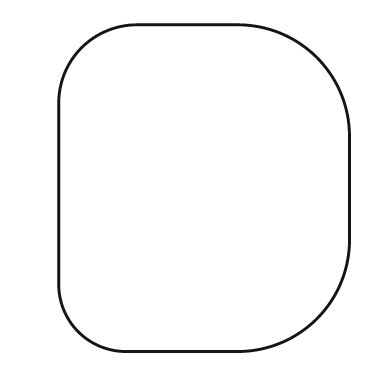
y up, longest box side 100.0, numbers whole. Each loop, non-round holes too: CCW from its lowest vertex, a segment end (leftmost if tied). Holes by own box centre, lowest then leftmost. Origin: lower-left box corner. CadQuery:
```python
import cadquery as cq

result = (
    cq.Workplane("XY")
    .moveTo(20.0, 0.0)
    .lineTo(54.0, 0.0)
    .threePointArc((79.0, 10.0), (89.0, 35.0))
    .lineTo(89.0, 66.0)
    .threePointArc((79.0, 90.0), (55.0, 100.0))
    .lineTo(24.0, 100.0)
    .threePointArc((7.0, 93.0), (0.0, 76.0))
    .lineTo(0.0, 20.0)
    .threePointArc((6.0, 6.0), (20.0, 0.0))
    .close()
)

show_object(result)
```